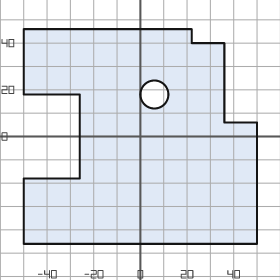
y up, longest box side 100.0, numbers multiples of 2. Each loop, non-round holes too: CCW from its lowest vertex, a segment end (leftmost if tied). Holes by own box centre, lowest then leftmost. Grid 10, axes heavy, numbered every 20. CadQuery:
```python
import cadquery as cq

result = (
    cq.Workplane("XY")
    .moveTo(-50.0, -46.0)
    .lineTo(50.0, -46.0)
    .lineTo(50.0, 6.0)
    .lineTo(36.0, 6.0)
    .lineTo(36.0, 40.0)
    .lineTo(22.0, 40.0)
    .lineTo(22.0, 46.0)
    .lineTo(-50.0, 46.0)
    .lineTo(-50.0, 18.0)
    .lineTo(-26.0, 18.0)
    .lineTo(-26.0, -18.0)
    .lineTo(-50.0, -18.0)
    .close()
    .moveTo(6.0, 18.0)
    .circle(6.0)
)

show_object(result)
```